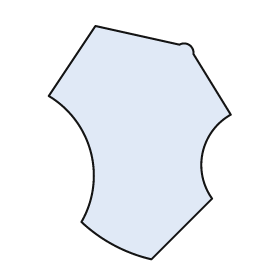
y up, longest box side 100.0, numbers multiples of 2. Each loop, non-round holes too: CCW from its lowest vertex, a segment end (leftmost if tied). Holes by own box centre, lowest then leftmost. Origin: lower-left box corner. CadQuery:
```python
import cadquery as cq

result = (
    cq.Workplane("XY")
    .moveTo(44.0, 0.0)
    .lineTo(70.0, 26.0)
    .threePointArc((66.0, 46.0), (78.0, 62.0))
    .lineTo(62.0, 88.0)
    .threePointArc((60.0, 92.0), (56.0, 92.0))
    .lineTo(20.0, 100.0)
    .lineTo(0.0, 70.0)
    .threePointArc((18.0, 46.0), (14.0, 16.0))
    .threePointArc((28.0, 6.0), (44.0, 0.0))
    .close()
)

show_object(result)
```